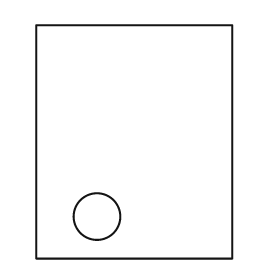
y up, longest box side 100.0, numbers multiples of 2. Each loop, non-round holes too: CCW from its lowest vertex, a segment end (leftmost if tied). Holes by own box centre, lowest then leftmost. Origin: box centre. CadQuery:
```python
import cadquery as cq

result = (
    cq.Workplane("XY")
    .moveTo(-42.0, -50.0)
    .lineTo(42.0, -50.0)
    .lineTo(42.0, 50.0)
    .lineTo(-42.0, 50.0)
    .close()
    .moveTo(-16.0, -32.0)
    .circle(10.0)
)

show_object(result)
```